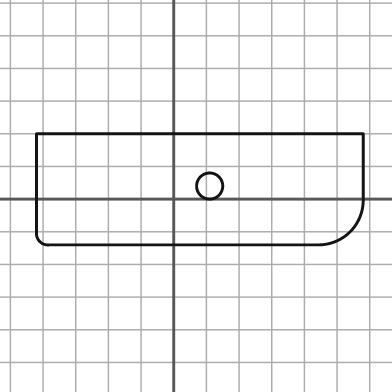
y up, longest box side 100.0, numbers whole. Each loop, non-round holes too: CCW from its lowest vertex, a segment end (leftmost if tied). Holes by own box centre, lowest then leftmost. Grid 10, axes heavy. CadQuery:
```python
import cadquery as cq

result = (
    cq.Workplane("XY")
    .moveTo(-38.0, -14.0)
    .lineTo(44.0, -14.0)
    .threePointArc((54.0, -10.0), (58.0, 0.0))
    .lineTo(58.0, 20.0)
    .lineTo(-42.0, 20.0)
    .lineTo(-42.0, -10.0)
    .threePointArc((-41.0, -13.0), (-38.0, -14.0))
    .close()
    .moveTo(11.0, 4.0)
    .circle(4.0)
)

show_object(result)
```